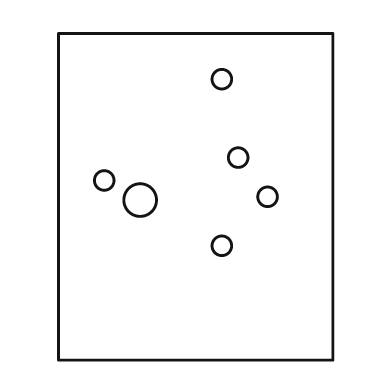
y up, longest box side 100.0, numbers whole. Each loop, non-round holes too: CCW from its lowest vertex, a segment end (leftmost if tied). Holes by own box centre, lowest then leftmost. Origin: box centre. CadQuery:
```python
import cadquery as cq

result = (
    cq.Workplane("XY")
    .moveTo(-42.0, -50.0)
    .lineTo(42.0, -50.0)
    .lineTo(42.0, 50.0)
    .lineTo(-42.0, 50.0)
    .close()
    .moveTo(8.0, -15.0)
    .circle(3.0)
    .moveTo(-17.0, -1.0)
    .circle(5.0)
    .moveTo(22.0, 0.0)
    .circle(3.0)
    .moveTo(-28.0, 5.0)
    .circle(3.0)
    .moveTo(13.0, 12.0)
    .circle(3.0)
    .moveTo(8.0, 36.0)
    .circle(3.0)
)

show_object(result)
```